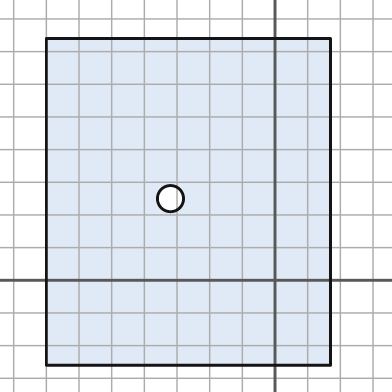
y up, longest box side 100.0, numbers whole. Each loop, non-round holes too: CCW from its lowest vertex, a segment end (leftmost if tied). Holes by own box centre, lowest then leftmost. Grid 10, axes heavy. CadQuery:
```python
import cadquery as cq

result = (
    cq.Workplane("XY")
    .moveTo(-70.0, -26.0)
    .lineTo(17.0, -26.0)
    .lineTo(17.0, 74.0)
    .lineTo(-70.0, 74.0)
    .close()
    .moveTo(-32.0, 25.0)
    .circle(4.0)
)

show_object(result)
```